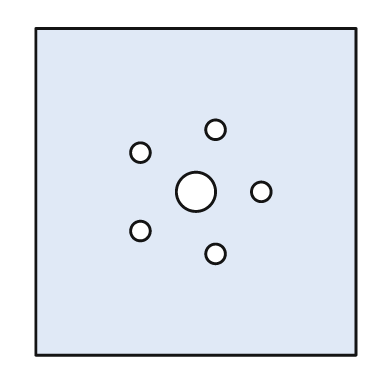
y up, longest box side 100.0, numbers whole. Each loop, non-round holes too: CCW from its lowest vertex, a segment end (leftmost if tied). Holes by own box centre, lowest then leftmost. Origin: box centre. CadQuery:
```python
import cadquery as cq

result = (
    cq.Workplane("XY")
    .moveTo(-49.0, -50.0)
    .lineTo(49.0, -50.0)
    .lineTo(49.0, 50.0)
    .lineTo(-49.0, 50.0)
    .close()
    .moveTo(6.0, -19.0)
    .circle(3.0)
    .moveTo(-17.0, -12.0)
    .circle(3.0)
    .moveTo(0.0, 0.0)
    .circle(6.0)
    .moveTo(20.0, 0.0)
    .circle(3.0)
    .moveTo(-17.0, 12.0)
    .circle(3.0)
    .moveTo(6.0, 19.0)
    .circle(3.0)
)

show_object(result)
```